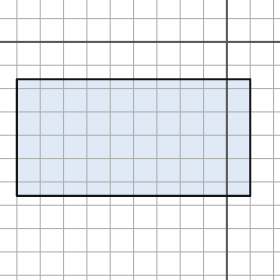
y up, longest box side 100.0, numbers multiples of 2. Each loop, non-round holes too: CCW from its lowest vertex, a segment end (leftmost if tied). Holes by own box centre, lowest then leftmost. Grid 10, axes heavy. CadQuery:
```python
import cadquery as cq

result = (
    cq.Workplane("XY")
    .moveTo(-90.0, -66.0)
    .lineTo(10.0, -66.0)
    .lineTo(10.0, -16.0)
    .lineTo(-90.0, -16.0)
    .close()
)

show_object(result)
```